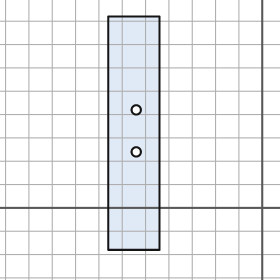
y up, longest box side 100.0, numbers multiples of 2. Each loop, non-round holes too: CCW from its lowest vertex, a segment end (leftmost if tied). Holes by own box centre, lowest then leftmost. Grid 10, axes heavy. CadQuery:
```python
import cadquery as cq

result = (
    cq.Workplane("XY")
    .moveTo(-66.0, -18.0)
    .lineTo(-44.0, -18.0)
    .lineTo(-44.0, 82.0)
    .lineTo(-66.0, 82.0)
    .close()
    .moveTo(-54.0, 24.0)
    .circle(2.0)
    .moveTo(-54.0, 42.0)
    .circle(2.0)
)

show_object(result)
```